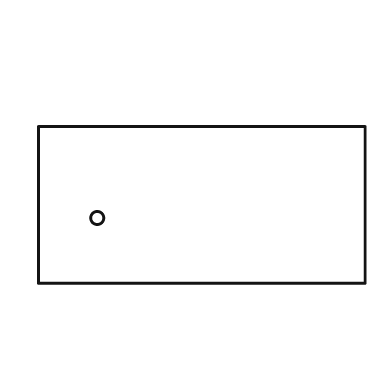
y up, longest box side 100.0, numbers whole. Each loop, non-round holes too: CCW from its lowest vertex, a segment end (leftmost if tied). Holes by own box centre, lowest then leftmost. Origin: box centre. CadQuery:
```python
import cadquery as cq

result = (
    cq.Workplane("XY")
    .moveTo(-50.0, -24.0)
    .lineTo(50.0, -24.0)
    .lineTo(50.0, 24.0)
    .lineTo(-50.0, 24.0)
    .close()
    .moveTo(-32.0, -4.0)
    .circle(2.0)
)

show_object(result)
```